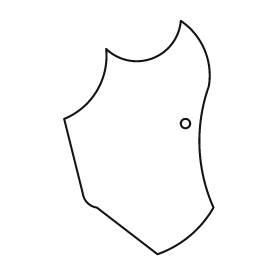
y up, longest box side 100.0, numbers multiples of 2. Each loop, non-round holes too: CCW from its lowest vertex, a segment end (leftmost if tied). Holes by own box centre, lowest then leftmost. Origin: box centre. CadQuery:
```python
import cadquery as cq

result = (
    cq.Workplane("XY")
    .moveTo(8.0, -50.0)
    .threePointArc((22.0, -42.0), (32.0, -30.0))
    .threePointArc((26.0, -4.0), (30.0, 22.0))
    .threePointArc((28.0, 38.0), (18.0, 50.0))
    .threePointArc((6.0, 34.0), (-14.0, 38.0))
    .threePointArc((-18.0, 20.0), (-32.0, 8.0))
    .lineTo(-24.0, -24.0)
    .threePointArc((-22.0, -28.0), (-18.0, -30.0))
    .close()
    .moveTo(20.0, 6.0)
    .circle(2.0)
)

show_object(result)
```